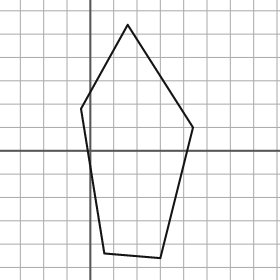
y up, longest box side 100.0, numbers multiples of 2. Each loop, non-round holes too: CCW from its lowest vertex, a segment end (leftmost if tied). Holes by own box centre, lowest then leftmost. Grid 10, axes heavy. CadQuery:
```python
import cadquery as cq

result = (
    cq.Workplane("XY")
    .moveTo(30.0, -46.0)
    .lineTo(44.0, 10.0)
    .lineTo(16.0, 54.0)
    .lineTo(-4.0, 18.0)
    .lineTo(6.0, -44.0)
    .close()
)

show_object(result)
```